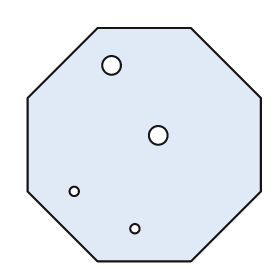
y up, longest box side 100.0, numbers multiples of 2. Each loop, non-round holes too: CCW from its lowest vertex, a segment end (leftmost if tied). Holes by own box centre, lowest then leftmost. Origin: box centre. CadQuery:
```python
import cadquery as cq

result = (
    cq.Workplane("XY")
    .moveTo(-20.0, -50.0)
    .lineTo(20.0, -50.0)
    .lineTo(50.0, -20.0)
    .lineTo(50.0, 20.0)
    .lineTo(20.0, 50.0)
    .lineTo(-20.0, 50.0)
    .lineTo(-50.0, 20.0)
    .lineTo(-50.0, -20.0)
    .close()
    .moveTo(-4.0, -36.0)
    .circle(2.0)
    .moveTo(-30.0, -20.0)
    .circle(2.0)
    .moveTo(6.0, 4.0)
    .circle(4.0)
    .moveTo(-14.0, 34.0)
    .circle(4.0)
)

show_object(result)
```